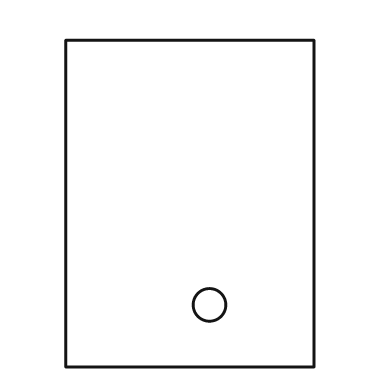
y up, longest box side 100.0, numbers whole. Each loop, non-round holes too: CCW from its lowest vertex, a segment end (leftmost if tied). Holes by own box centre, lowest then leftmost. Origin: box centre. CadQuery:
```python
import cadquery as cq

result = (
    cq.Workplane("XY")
    .moveTo(-38.0, -50.0)
    .lineTo(38.0, -50.0)
    .lineTo(38.0, 50.0)
    .lineTo(-38.0, 50.0)
    .close()
    .moveTo(6.0, -31.0)
    .circle(5.0)
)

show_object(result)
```